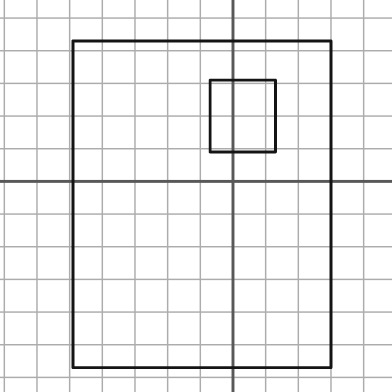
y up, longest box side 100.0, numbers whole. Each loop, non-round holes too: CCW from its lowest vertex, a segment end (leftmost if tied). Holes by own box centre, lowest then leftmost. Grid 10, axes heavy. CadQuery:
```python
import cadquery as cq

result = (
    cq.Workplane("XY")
    .moveTo(-49.0, -57.0)
    .lineTo(30.0, -57.0)
    .lineTo(30.0, 43.0)
    .lineTo(-49.0, 43.0)
    .close()
    .moveTo(-7.0, 9.0)
    .lineTo(13.0, 9.0)
    .lineTo(13.0, 31.0)
    .lineTo(-7.0, 31.0)
    .close()
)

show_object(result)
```